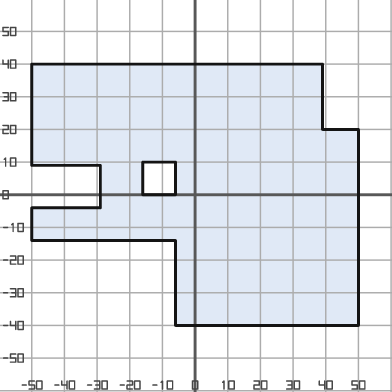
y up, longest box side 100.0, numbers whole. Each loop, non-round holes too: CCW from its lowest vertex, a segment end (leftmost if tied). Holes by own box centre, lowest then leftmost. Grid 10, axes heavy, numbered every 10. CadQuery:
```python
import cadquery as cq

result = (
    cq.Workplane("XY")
    .moveTo(-6.0, -40.0)
    .lineTo(50.0, -40.0)
    .lineTo(50.0, 20.0)
    .lineTo(39.0, 20.0)
    .lineTo(39.0, 40.0)
    .lineTo(-50.0, 40.0)
    .lineTo(-50.0, 9.0)
    .lineTo(-29.0, 9.0)
    .lineTo(-29.0, -4.0)
    .lineTo(-50.0, -4.0)
    .lineTo(-50.0, -14.0)
    .lineTo(-6.0, -14.0)
    .close()
    .moveTo(-16.0, 0.0)
    .lineTo(-6.0, 0.0)
    .lineTo(-6.0, 10.0)
    .lineTo(-16.0, 10.0)
    .close()
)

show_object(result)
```